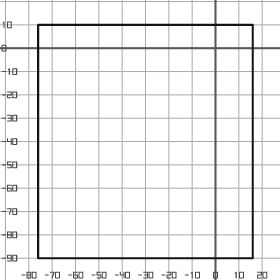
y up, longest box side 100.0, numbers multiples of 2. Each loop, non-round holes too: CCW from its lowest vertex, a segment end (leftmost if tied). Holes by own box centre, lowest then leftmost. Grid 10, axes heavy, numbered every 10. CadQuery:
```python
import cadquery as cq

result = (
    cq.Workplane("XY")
    .moveTo(-76.0, -90.0)
    .lineTo(16.0, -90.0)
    .lineTo(16.0, 10.0)
    .lineTo(-76.0, 10.0)
    .close()
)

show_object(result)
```